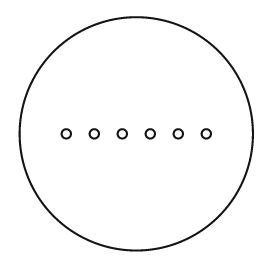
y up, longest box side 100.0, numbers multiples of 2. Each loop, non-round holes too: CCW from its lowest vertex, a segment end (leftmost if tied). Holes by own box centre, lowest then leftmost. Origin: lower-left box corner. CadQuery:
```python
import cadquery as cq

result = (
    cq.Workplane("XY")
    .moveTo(50.0, 50.0)
    .circle(50.0)
    .moveTo(20.0, 50.0)
    .circle(2.0)
    .moveTo(32.0, 50.0)
    .circle(2.0)
    .moveTo(44.0, 50.0)
    .circle(2.0)
    .moveTo(56.0, 50.0)
    .circle(2.0)
    .moveTo(68.0, 50.0)
    .circle(2.0)
    .moveTo(80.0, 50.0)
    .circle(2.0)
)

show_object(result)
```